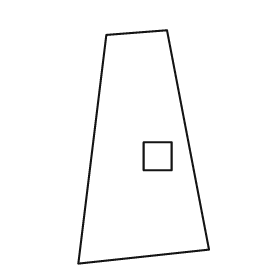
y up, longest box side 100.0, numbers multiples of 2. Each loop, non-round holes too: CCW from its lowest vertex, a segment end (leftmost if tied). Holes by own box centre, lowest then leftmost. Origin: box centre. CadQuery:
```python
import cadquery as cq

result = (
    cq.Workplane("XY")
    .moveTo(-28.0, -50.0)
    .lineTo(28.0, -44.0)
    .lineTo(10.0, 50.0)
    .lineTo(-16.0, 48.0)
    .close()
    .moveTo(0.0, -10.0)
    .lineTo(12.0, -10.0)
    .lineTo(12.0, 2.0)
    .lineTo(0.0, 2.0)
    .close()
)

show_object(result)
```